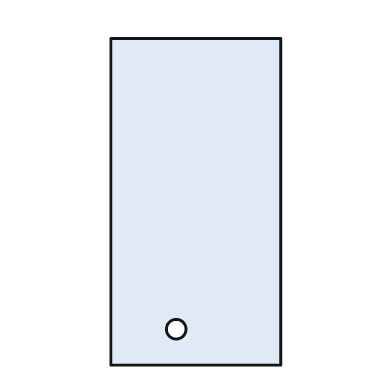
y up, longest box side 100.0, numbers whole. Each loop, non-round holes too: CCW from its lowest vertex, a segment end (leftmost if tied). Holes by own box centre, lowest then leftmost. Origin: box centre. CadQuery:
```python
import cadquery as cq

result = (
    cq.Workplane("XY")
    .moveTo(-26.0, -50.0)
    .lineTo(26.0, -50.0)
    .lineTo(26.0, 50.0)
    .lineTo(-26.0, 50.0)
    .close()
    .moveTo(-6.0, -39.0)
    .circle(3.0)
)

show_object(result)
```